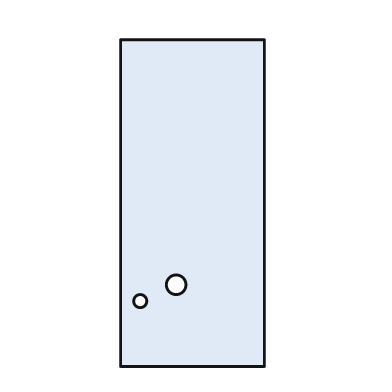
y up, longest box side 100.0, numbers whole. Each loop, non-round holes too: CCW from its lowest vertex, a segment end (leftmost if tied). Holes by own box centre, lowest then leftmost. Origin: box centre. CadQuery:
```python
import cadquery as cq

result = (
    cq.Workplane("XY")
    .moveTo(-22.0, -50.0)
    .lineTo(22.0, -50.0)
    .lineTo(22.0, 50.0)
    .lineTo(-22.0, 50.0)
    .close()
    .moveTo(-16.0, -30.0)
    .circle(2.0)
    .moveTo(-5.0, -25.0)
    .circle(3.0)
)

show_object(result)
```